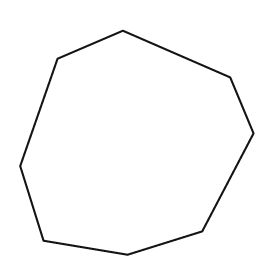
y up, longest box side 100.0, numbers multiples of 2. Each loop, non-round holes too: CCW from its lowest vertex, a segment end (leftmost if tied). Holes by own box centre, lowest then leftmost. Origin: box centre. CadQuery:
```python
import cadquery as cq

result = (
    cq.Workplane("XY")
    .moveTo(-4.0, -48.0)
    .lineTo(28.0, -38.0)
    .lineTo(50.0, 4.0)
    .lineTo(40.0, 28.0)
    .lineTo(-6.0, 48.0)
    .lineTo(-34.0, 36.0)
    .lineTo(-50.0, -10.0)
    .lineTo(-40.0, -42.0)
    .close()
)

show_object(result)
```